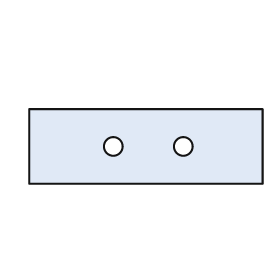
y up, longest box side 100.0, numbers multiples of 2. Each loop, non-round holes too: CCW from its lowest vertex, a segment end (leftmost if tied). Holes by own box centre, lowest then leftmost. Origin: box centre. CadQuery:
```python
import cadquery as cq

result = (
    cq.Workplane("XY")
    .moveTo(-50.0, -16.0)
    .lineTo(50.0, -16.0)
    .lineTo(50.0, 16.0)
    .lineTo(-50.0, 16.0)
    .close()
    .moveTo(-14.0, 0.0)
    .circle(4.0)
    .moveTo(16.0, 0.0)
    .circle(4.0)
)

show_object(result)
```